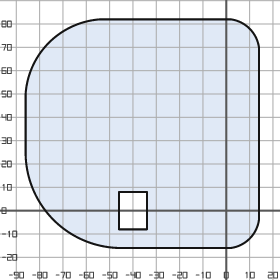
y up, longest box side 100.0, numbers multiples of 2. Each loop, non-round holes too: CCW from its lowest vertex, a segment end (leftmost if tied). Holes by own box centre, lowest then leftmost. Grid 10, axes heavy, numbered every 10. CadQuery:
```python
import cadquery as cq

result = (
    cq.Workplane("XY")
    .moveTo(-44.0, -16.0)
    .lineTo(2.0, -16.0)
    .threePointArc((10.0, -12.0), (14.0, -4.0))
    .lineTo(14.0, 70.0)
    .threePointArc((10.0, 78.0), (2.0, 82.0))
    .lineTo(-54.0, 82.0)
    .threePointArc((-76.0, 72.0), (-86.0, 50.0))
    .lineTo(-86.0, 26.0)
    .threePointArc((-74.0, -4.0), (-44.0, -16.0))
    .close()
    .moveTo(-46.0, -8.0)
    .lineTo(-34.0, -8.0)
    .lineTo(-34.0, 8.0)
    .lineTo(-46.0, 8.0)
    .close()
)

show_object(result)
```